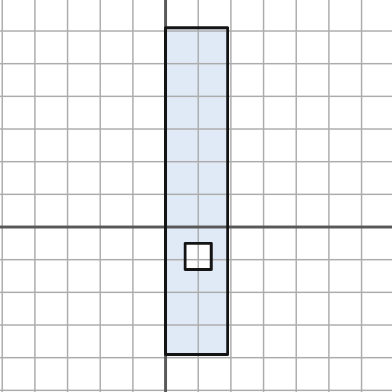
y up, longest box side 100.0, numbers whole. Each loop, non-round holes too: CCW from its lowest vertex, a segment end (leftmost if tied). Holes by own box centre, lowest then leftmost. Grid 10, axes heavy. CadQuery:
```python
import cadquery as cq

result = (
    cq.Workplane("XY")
    .moveTo(0.0, -39.0)
    .lineTo(19.0, -39.0)
    .lineTo(19.0, 61.0)
    .lineTo(0.0, 61.0)
    .close()
    .moveTo(6.0, -13.0)
    .lineTo(14.0, -13.0)
    .lineTo(14.0, -5.0)
    .lineTo(6.0, -5.0)
    .close()
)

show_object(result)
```